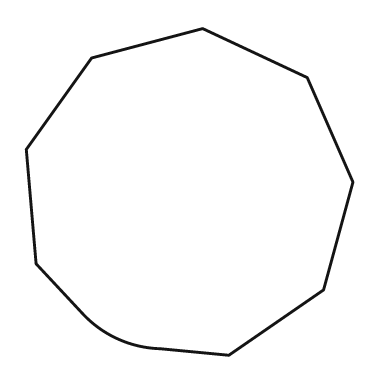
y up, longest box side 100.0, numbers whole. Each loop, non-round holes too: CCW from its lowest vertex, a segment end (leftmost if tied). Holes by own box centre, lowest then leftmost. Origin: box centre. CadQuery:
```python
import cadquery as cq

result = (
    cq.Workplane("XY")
    .moveTo(12.0, -50.0)
    .lineTo(41.0, -30.0)
    .lineTo(50.0, 3.0)
    .lineTo(36.0, 35.0)
    .lineTo(4.0, 50.0)
    .lineTo(-30.0, 41.0)
    .lineTo(-50.0, 13.0)
    .lineTo(-47.0, -22.0)
    .lineTo(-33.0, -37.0)
    .threePointArc((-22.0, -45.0), (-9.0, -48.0))
    .close()
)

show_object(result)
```